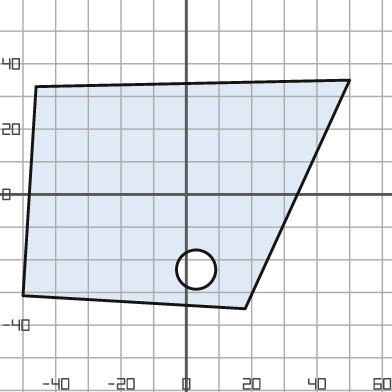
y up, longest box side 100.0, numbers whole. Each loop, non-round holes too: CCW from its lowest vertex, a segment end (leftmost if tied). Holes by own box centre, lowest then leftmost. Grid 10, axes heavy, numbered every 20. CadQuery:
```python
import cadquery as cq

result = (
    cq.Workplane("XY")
    .moveTo(18.0, -35.0)
    .lineTo(50.0, 35.0)
    .lineTo(-46.0, 33.0)
    .lineTo(-50.0, -31.0)
    .close()
    .moveTo(3.0, -23.0)
    .circle(6.0)
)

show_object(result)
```